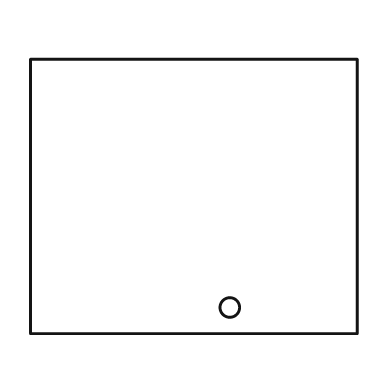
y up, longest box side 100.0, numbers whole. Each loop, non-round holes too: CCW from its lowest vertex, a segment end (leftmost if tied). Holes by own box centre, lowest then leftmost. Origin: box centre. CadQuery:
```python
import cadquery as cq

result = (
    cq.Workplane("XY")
    .moveTo(-50.0, -42.0)
    .lineTo(50.0, -42.0)
    .lineTo(50.0, 42.0)
    .lineTo(-50.0, 42.0)
    .close()
    .moveTo(11.0, -34.0)
    .circle(3.0)
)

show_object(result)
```